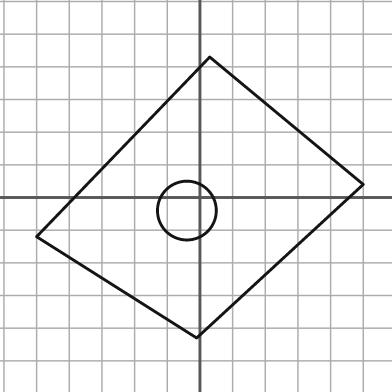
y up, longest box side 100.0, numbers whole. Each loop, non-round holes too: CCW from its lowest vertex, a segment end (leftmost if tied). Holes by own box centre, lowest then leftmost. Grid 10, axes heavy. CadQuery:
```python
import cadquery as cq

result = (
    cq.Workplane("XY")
    .moveTo(-1.0, -43.0)
    .lineTo(50.0, 4.0)
    .lineTo(3.0, 43.0)
    .lineTo(-50.0, -12.0)
    .close()
    .moveTo(-4.0, -4.0)
    .circle(9.0)
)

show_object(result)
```